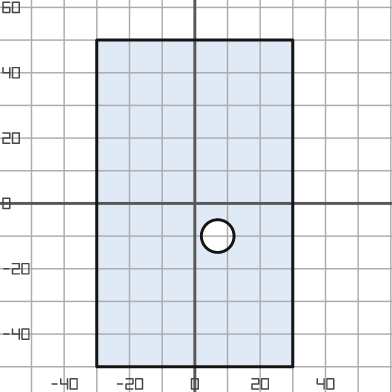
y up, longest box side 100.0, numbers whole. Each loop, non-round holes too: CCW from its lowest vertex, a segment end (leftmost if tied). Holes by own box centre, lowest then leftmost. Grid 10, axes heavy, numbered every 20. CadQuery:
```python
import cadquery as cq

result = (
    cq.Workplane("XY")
    .moveTo(-30.0, -50.0)
    .lineTo(30.0, -50.0)
    .lineTo(30.0, 50.0)
    .lineTo(-30.0, 50.0)
    .close()
    .moveTo(7.0, -10.0)
    .circle(5.0)
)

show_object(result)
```